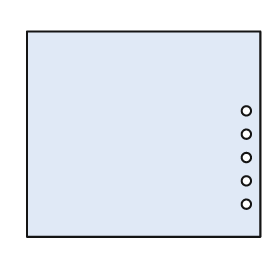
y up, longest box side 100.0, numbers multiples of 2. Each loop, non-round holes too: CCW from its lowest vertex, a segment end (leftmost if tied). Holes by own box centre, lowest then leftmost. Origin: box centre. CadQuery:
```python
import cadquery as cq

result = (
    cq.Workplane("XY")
    .moveTo(-50.0, -44.0)
    .lineTo(50.0, -44.0)
    .lineTo(50.0, 44.0)
    .lineTo(-50.0, 44.0)
    .close()
    .moveTo(44.0, -30.0)
    .circle(2.0)
    .moveTo(44.0, -20.0)
    .circle(2.0)
    .moveTo(44.0, -10.0)
    .circle(2.0)
    .moveTo(44.0, 0.0)
    .circle(2.0)
    .moveTo(44.0, 10.0)
    .circle(2.0)
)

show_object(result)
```